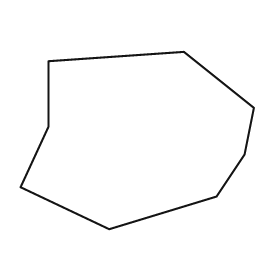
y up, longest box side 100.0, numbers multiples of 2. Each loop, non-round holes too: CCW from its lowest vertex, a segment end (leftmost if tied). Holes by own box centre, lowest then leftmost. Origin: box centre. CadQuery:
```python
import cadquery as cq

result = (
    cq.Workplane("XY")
    .moveTo(-12.0, -38.0)
    .lineTo(34.0, -24.0)
    .lineTo(46.0, -6.0)
    .lineTo(50.0, 14.0)
    .lineTo(20.0, 38.0)
    .lineTo(-38.0, 34.0)
    .lineTo(-38.0, 6.0)
    .lineTo(-50.0, -20.0)
    .close()
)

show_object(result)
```